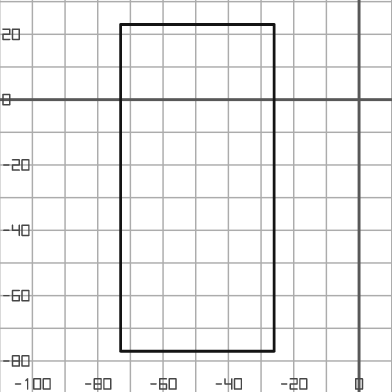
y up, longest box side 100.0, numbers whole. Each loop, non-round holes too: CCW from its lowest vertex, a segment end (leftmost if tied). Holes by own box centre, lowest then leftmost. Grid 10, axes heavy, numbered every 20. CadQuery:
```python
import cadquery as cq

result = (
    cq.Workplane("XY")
    .moveTo(-73.0, -77.0)
    .lineTo(-26.0, -77.0)
    .lineTo(-26.0, 23.0)
    .lineTo(-73.0, 23.0)
    .close()
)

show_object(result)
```